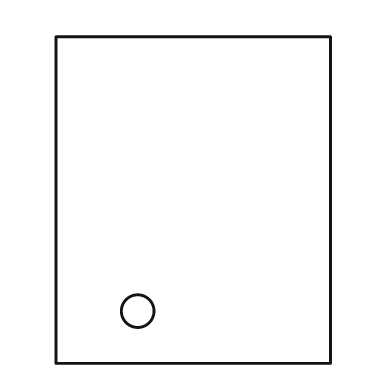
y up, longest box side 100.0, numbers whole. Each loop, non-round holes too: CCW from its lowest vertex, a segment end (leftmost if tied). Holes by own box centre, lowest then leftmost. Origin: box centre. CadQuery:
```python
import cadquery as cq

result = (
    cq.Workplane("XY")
    .moveTo(-42.0, -50.0)
    .lineTo(42.0, -50.0)
    .lineTo(42.0, 50.0)
    .lineTo(-42.0, 50.0)
    .close()
    .moveTo(-17.0, -34.0)
    .circle(5.0)
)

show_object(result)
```